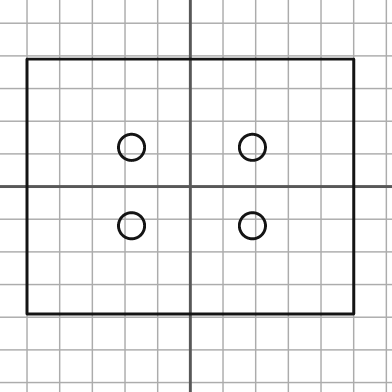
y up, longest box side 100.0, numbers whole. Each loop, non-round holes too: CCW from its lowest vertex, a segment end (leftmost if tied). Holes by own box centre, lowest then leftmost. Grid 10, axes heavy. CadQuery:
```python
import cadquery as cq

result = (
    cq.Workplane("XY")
    .moveTo(-50.0, -39.0)
    .lineTo(50.0, -39.0)
    .lineTo(50.0, 39.0)
    .lineTo(-50.0, 39.0)
    .close()
    .moveTo(-18.0, -12.0)
    .circle(4.0)
    .moveTo(19.0, -12.0)
    .circle(4.0)
    .moveTo(-18.0, 12.0)
    .circle(4.0)
    .moveTo(19.0, 12.0)
    .circle(4.0)
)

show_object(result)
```